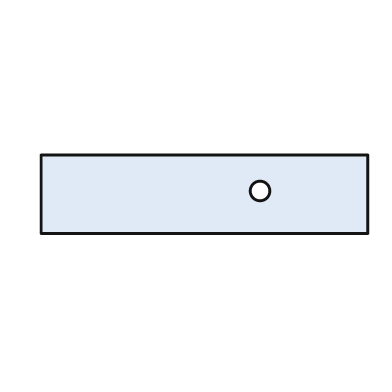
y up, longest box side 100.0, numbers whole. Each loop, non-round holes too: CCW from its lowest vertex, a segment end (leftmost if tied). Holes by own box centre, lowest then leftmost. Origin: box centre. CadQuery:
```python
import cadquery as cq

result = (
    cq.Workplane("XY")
    .moveTo(-50.0, -12.0)
    .lineTo(50.0, -12.0)
    .lineTo(50.0, 12.0)
    .lineTo(-50.0, 12.0)
    .close()
    .moveTo(17.0, 1.0)
    .circle(3.0)
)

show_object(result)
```